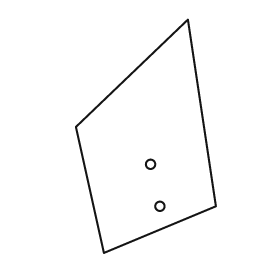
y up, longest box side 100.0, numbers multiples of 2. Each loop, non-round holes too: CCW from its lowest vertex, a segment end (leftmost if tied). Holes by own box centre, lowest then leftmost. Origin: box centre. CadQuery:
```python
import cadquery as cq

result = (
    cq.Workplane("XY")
    .moveTo(-18.0, -50.0)
    .lineTo(30.0, -30.0)
    .lineTo(18.0, 50.0)
    .lineTo(-30.0, 4.0)
    .close()
    .moveTo(6.0, -30.0)
    .circle(2.0)
    .moveTo(2.0, -12.0)
    .circle(2.0)
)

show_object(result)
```